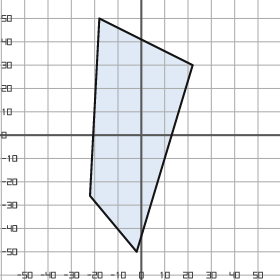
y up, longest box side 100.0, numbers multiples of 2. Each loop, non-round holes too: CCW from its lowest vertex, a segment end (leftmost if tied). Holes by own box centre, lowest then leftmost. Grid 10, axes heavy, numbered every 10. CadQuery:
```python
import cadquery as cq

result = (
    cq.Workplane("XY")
    .moveTo(-2.0, -50.0)
    .lineTo(22.0, 30.0)
    .lineTo(-18.0, 50.0)
    .lineTo(-22.0, -26.0)
    .close()
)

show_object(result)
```